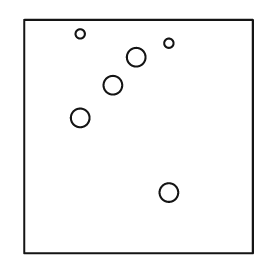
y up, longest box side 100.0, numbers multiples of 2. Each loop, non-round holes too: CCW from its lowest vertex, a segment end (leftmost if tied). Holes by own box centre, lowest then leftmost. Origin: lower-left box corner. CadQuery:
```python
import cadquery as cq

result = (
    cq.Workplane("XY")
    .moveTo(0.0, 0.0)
    .lineTo(98.0, 0.0)
    .lineTo(98.0, 100.0)
    .lineTo(0.0, 100.0)
    .close()
    .moveTo(62.0, 26.0)
    .circle(4.0)
    .moveTo(24.0, 58.0)
    .circle(4.0)
    .moveTo(38.0, 72.0)
    .circle(4.0)
    .moveTo(48.0, 84.0)
    .circle(4.0)
    .moveTo(62.0, 90.0)
    .circle(2.0)
    .moveTo(24.0, 94.0)
    .circle(2.0)
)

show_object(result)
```